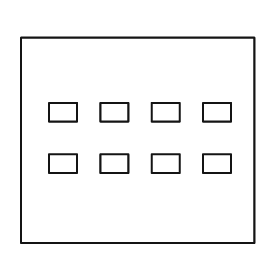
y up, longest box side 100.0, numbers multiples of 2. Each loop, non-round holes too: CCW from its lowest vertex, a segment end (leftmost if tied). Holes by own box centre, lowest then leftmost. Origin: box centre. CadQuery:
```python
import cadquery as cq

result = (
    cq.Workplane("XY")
    .moveTo(-50.0, -44.0)
    .lineTo(50.0, -44.0)
    .lineTo(50.0, 44.0)
    .lineTo(-50.0, 44.0)
    .close()
    .moveTo(-38.0, -14.0)
    .lineTo(-26.0, -14.0)
    .lineTo(-26.0, -6.0)
    .lineTo(-38.0, -6.0)
    .close()
    .moveTo(-16.0, -14.0)
    .lineTo(-4.0, -14.0)
    .lineTo(-4.0, -6.0)
    .lineTo(-16.0, -6.0)
    .close()
    .moveTo(6.0, -14.0)
    .lineTo(18.0, -14.0)
    .lineTo(18.0, -6.0)
    .lineTo(6.0, -6.0)
    .close()
    .moveTo(28.0, -14.0)
    .lineTo(40.0, -14.0)
    .lineTo(40.0, -6.0)
    .lineTo(28.0, -6.0)
    .close()
    .moveTo(-38.0, 8.0)
    .lineTo(-26.0, 8.0)
    .lineTo(-26.0, 16.0)
    .lineTo(-38.0, 16.0)
    .close()
    .moveTo(-16.0, 8.0)
    .lineTo(-4.0, 8.0)
    .lineTo(-4.0, 16.0)
    .lineTo(-16.0, 16.0)
    .close()
    .moveTo(6.0, 8.0)
    .lineTo(18.0, 8.0)
    .lineTo(18.0, 16.0)
    .lineTo(6.0, 16.0)
    .close()
    .moveTo(28.0, 8.0)
    .lineTo(40.0, 8.0)
    .lineTo(40.0, 16.0)
    .lineTo(28.0, 16.0)
    .close()
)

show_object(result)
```